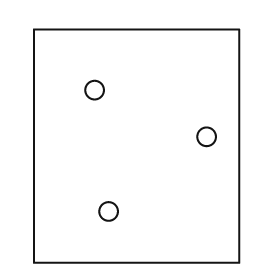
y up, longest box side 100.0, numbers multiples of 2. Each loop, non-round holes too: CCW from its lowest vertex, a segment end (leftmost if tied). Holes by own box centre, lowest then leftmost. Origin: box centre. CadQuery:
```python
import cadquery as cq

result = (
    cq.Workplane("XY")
    .moveTo(-44.0, -50.0)
    .lineTo(44.0, -50.0)
    .lineTo(44.0, 50.0)
    .lineTo(-44.0, 50.0)
    .close()
    .moveTo(-12.0, -28.0)
    .circle(4.0)
    .moveTo(30.0, 4.0)
    .circle(4.0)
    .moveTo(-18.0, 24.0)
    .circle(4.0)
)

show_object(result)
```